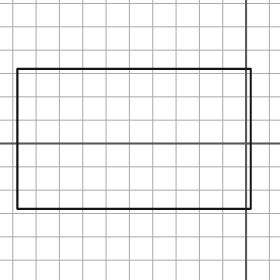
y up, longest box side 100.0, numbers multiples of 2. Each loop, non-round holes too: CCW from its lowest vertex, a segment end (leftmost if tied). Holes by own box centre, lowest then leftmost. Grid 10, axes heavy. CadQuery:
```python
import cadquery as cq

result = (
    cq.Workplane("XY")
    .moveTo(-98.0, -28.0)
    .lineTo(2.0, -28.0)
    .lineTo(2.0, 32.0)
    .lineTo(-98.0, 32.0)
    .close()
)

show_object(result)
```